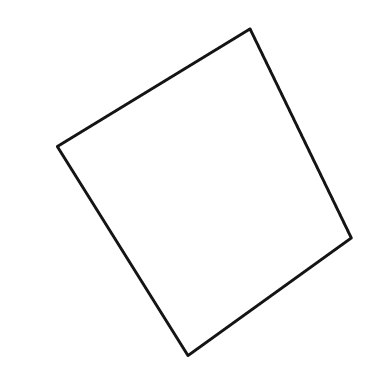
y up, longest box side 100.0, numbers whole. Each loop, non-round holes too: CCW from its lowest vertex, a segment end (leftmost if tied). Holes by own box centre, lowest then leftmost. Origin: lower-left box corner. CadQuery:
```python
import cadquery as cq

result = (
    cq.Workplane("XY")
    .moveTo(40.0, 0.0)
    .lineTo(90.0, 36.0)
    .lineTo(59.0, 100.0)
    .lineTo(0.0, 64.0)
    .close()
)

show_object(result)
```